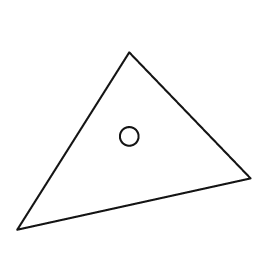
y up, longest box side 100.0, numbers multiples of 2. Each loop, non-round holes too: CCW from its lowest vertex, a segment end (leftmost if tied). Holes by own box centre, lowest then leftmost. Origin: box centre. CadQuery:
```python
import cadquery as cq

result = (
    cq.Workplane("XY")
    .moveTo(-50.0, -38.0)
    .lineTo(50.0, -16.0)
    .lineTo(-2.0, 38.0)
    .close()
    .moveTo(-2.0, 2.0)
    .circle(4.0)
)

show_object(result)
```